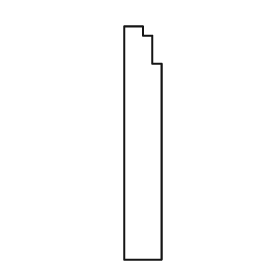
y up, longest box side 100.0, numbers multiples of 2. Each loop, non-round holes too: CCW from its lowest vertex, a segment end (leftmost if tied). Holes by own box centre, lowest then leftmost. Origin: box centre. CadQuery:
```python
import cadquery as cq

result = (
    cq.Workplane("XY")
    .moveTo(-8.0, -50.0)
    .lineTo(8.0, -50.0)
    .lineTo(8.0, 34.0)
    .lineTo(4.0, 34.0)
    .lineTo(4.0, 46.0)
    .lineTo(0.0, 46.0)
    .lineTo(0.0, 50.0)
    .lineTo(-8.0, 50.0)
    .close()
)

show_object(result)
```